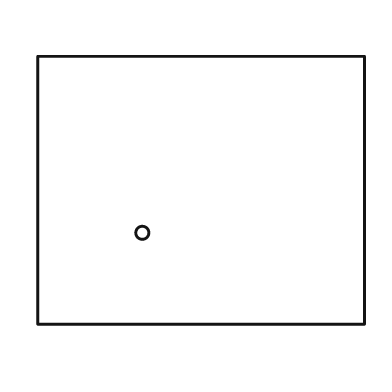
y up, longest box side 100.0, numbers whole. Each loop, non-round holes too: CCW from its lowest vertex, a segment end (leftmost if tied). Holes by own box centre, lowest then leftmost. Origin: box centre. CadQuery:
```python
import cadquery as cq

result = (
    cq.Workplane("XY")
    .moveTo(-50.0, -41.0)
    .lineTo(50.0, -41.0)
    .lineTo(50.0, 41.0)
    .lineTo(-50.0, 41.0)
    .close()
    .moveTo(-18.0, -13.0)
    .circle(2.0)
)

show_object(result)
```